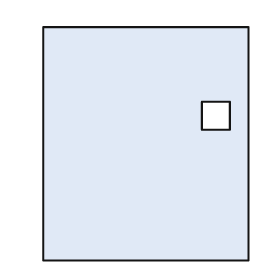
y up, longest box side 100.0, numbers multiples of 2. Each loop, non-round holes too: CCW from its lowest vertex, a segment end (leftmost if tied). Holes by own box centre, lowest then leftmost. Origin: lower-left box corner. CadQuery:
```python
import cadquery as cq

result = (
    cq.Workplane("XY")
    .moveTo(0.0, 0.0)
    .lineTo(88.0, 0.0)
    .lineTo(88.0, 100.0)
    .lineTo(0.0, 100.0)
    .close()
    .moveTo(68.0, 56.0)
    .lineTo(80.0, 56.0)
    .lineTo(80.0, 68.0)
    .lineTo(68.0, 68.0)
    .close()
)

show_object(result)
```